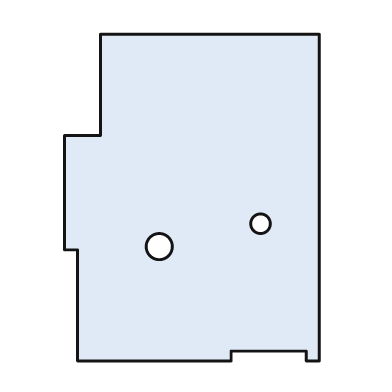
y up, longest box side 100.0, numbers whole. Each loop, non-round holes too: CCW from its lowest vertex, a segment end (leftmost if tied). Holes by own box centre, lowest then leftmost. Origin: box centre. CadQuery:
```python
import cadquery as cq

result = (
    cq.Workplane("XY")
    .moveTo(-35.0, -50.0)
    .lineTo(12.0, -50.0)
    .lineTo(12.0, -47.0)
    .lineTo(35.0, -47.0)
    .lineTo(35.0, -50.0)
    .lineTo(39.0, -50.0)
    .lineTo(39.0, 50.0)
    .lineTo(-28.0, 50.0)
    .lineTo(-28.0, 19.0)
    .lineTo(-39.0, 19.0)
    .lineTo(-39.0, -16.0)
    .lineTo(-35.0, -16.0)
    .close()
    .moveTo(-10.0, -15.0)
    .circle(4.0)
    .moveTo(21.0, -8.0)
    .circle(3.0)
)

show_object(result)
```